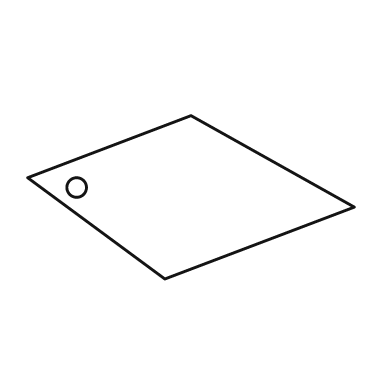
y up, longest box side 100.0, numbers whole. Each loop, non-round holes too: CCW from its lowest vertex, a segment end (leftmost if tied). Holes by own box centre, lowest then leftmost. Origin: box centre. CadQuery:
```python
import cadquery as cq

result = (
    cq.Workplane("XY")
    .moveTo(-8.0, -25.0)
    .lineTo(50.0, -3.0)
    .lineTo(0.0, 25.0)
    .lineTo(-50.0, 6.0)
    .close()
    .moveTo(-35.0, 3.0)
    .circle(3.0)
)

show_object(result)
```